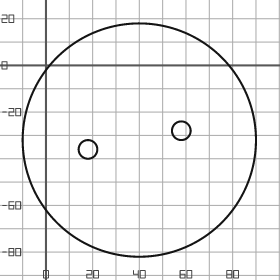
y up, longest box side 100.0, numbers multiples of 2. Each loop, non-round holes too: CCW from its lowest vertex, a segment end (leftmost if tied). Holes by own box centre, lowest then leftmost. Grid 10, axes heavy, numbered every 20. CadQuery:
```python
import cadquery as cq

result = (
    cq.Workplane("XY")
    .moveTo(40.0, -32.0)
    .circle(50.0)
    .moveTo(18.0, -36.0)
    .circle(4.0)
    .moveTo(58.0, -28.0)
    .circle(4.0)
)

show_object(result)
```